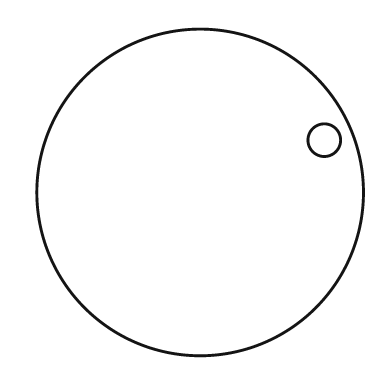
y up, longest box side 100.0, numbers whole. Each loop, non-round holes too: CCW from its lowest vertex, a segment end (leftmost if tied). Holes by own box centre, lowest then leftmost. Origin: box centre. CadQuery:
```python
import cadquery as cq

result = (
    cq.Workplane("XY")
    .moveTo(0.0, 0.0)
    .circle(50.0)
    .moveTo(38.0, 16.0)
    .circle(5.0)
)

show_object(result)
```